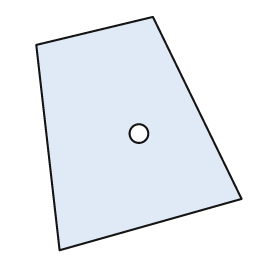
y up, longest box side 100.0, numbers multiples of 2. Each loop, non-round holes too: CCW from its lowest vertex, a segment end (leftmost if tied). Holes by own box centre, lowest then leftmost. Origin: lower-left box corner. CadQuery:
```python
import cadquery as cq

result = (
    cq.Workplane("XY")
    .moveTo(10.0, 0.0)
    .lineTo(88.0, 22.0)
    .lineTo(50.0, 100.0)
    .lineTo(0.0, 88.0)
    .close()
    .moveTo(44.0, 50.0)
    .circle(4.0)
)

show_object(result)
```